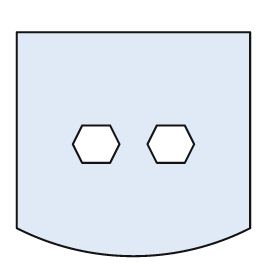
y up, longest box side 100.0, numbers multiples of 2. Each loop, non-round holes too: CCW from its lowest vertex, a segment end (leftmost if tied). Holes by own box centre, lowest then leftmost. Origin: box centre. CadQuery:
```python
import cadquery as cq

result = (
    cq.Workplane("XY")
    .moveTo(-50.0, -36.0)
    .threePointArc((0.0, -48.0), (50.0, -36.0))
    .lineTo(50.0, 48.0)
    .lineTo(-50.0, 48.0)
    .close()
    .moveTo(-22.0, -8.0)
    .lineTo(-10.0, -8.0)
    .lineTo(-6.0, 0.0)
    .lineTo(-10.0, 8.0)
    .lineTo(-22.0, 8.0)
    .lineTo(-26.0, 0.0)
    .close()
    .moveTo(10.0, -8.0)
    .lineTo(22.0, -8.0)
    .lineTo(26.0, 0.0)
    .lineTo(22.0, 8.0)
    .lineTo(10.0, 8.0)
    .lineTo(6.0, 0.0)
    .close()
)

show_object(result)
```